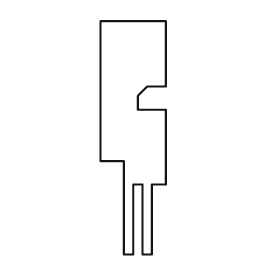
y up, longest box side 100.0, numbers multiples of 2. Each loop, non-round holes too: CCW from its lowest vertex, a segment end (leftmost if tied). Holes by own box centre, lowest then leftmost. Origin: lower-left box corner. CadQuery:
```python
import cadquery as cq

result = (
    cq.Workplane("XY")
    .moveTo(10.0, 0.0)
    .lineTo(14.0, 0.0)
    .lineTo(14.0, 30.0)
    .lineTo(18.0, 30.0)
    .lineTo(18.0, 0.0)
    .lineTo(22.0, 0.0)
    .lineTo(22.0, 30.0)
    .lineTo(28.0, 30.0)
    .lineTo(28.0, 62.0)
    .lineTo(16.0, 62.0)
    .lineTo(16.0, 68.0)
    .lineTo(20.0, 72.0)
    .lineTo(28.0, 72.0)
    .lineTo(28.0, 100.0)
    .lineTo(0.0, 100.0)
    .lineTo(0.0, 40.0)
    .lineTo(10.0, 40.0)
    .close()
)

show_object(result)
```